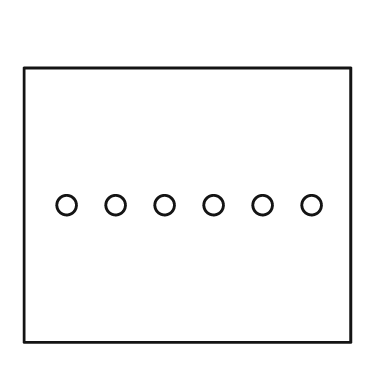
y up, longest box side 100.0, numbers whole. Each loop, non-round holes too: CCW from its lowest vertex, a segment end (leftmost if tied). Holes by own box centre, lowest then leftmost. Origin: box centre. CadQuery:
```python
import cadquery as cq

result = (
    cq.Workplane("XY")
    .moveTo(-50.0, -42.0)
    .lineTo(50.0, -42.0)
    .lineTo(50.0, 42.0)
    .lineTo(-50.0, 42.0)
    .close()
    .moveTo(-37.0, 0.0)
    .circle(3.0)
    .moveTo(-22.0, 0.0)
    .circle(3.0)
    .moveTo(-7.0, 0.0)
    .circle(3.0)
    .moveTo(8.0, 0.0)
    .circle(3.0)
    .moveTo(23.0, 0.0)
    .circle(3.0)
    .moveTo(38.0, 0.0)
    .circle(3.0)
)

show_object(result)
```